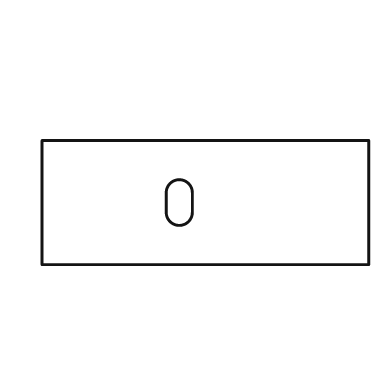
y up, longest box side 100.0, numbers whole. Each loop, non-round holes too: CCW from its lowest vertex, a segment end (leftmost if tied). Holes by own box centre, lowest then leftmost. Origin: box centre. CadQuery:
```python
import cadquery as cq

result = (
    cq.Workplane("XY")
    .moveTo(-50.0, -19.0)
    .lineTo(50.0, -19.0)
    .lineTo(50.0, 19.0)
    .lineTo(-50.0, 19.0)
    .close()
    .moveTo(-12.0, -3.0)
    .threePointArc((-8.0, -7.0), (-4.0, -3.0))
    .lineTo(-4.0, 3.0)
    .threePointArc((-8.0, 7.0), (-12.0, 3.0))
    .close()
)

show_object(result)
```